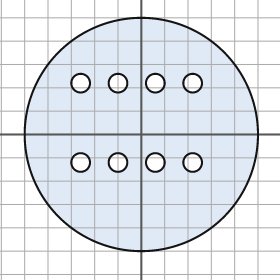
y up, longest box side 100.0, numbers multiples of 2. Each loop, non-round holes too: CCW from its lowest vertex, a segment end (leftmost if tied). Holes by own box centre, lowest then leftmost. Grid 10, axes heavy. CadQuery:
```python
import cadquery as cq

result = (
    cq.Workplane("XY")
    .moveTo(0.0, 0.0)
    .circle(50.0)
    .moveTo(-26.0, -12.0)
    .circle(4.0)
    .moveTo(-10.0, -12.0)
    .circle(4.0)
    .moveTo(6.0, -12.0)
    .circle(4.0)
    .moveTo(22.0, -12.0)
    .circle(4.0)
    .moveTo(-26.0, 22.0)
    .circle(4.0)
    .moveTo(-10.0, 22.0)
    .circle(4.0)
    .moveTo(6.0, 22.0)
    .circle(4.0)
    .moveTo(22.0, 22.0)
    .circle(4.0)
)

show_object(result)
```